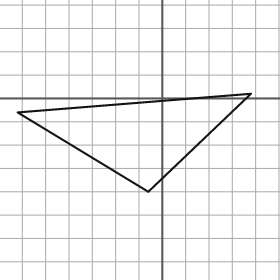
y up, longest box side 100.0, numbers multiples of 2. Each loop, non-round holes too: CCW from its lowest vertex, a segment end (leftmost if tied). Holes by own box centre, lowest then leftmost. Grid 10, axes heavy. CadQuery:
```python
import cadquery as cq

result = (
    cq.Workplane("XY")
    .moveTo(-6.0, -40.0)
    .lineTo(38.0, 2.0)
    .lineTo(-62.0, -6.0)
    .close()
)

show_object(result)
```